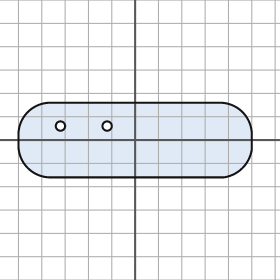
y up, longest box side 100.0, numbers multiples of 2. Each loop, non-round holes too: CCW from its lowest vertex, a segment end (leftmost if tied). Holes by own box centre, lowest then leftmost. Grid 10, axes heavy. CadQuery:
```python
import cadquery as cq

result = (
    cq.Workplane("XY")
    .moveTo(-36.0, -16.0)
    .lineTo(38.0, -16.0)
    .threePointArc((46.0, -12.0), (50.0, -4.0))
    .lineTo(50.0, 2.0)
    .threePointArc((46.0, 12.0), (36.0, 16.0))
    .lineTo(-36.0, 16.0)
    .threePointArc((-46.0, 12.0), (-50.0, 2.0))
    .lineTo(-50.0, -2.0)
    .threePointArc((-46.0, -12.0), (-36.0, -16.0))
    .close()
    .moveTo(-32.0, 6.0)
    .circle(2.0)
    .moveTo(-12.0, 6.0)
    .circle(2.0)
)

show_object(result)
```